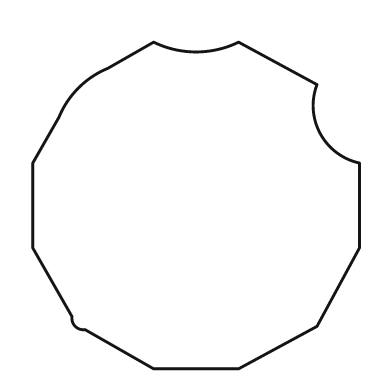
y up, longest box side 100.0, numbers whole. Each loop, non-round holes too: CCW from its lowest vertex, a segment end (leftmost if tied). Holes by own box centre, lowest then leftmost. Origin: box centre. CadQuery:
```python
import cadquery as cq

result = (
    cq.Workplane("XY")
    .moveTo(-13.0, -50.0)
    .lineTo(13.0, -50.0)
    .lineTo(37.0, -37.0)
    .lineTo(50.0, -13.0)
    .lineTo(50.0, 13.0)
    .threePointArc((38.0, 22.0), (37.0, 37.0))
    .lineTo(13.0, 50.0)
    .threePointArc((0.0, 47.0), (-13.0, 50.0))
    .lineTo(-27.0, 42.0)
    .threePointArc((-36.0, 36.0), (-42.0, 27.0))
    .lineTo(-50.0, 13.0)
    .lineTo(-50.0, -13.0)
    .lineTo(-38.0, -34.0)
    .threePointArc((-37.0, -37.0), (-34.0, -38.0))
    .close()
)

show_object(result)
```